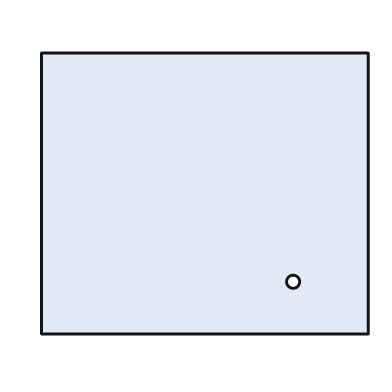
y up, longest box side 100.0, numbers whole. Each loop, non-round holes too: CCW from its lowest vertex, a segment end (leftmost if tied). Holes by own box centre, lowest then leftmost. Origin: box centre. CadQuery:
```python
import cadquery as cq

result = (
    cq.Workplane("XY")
    .moveTo(-50.0, -43.0)
    .lineTo(50.0, -43.0)
    .lineTo(50.0, 43.0)
    .lineTo(-50.0, 43.0)
    .close()
    .moveTo(27.0, -27.0)
    .circle(2.0)
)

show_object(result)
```